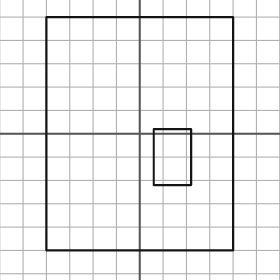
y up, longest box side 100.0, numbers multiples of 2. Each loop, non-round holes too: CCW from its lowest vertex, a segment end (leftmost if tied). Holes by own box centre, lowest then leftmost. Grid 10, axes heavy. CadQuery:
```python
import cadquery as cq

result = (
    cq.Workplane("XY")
    .moveTo(-40.0, -50.0)
    .lineTo(40.0, -50.0)
    .lineTo(40.0, 50.0)
    .lineTo(-40.0, 50.0)
    .close()
    .moveTo(6.0, -22.0)
    .lineTo(22.0, -22.0)
    .lineTo(22.0, 2.0)
    .lineTo(6.0, 2.0)
    .close()
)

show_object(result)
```